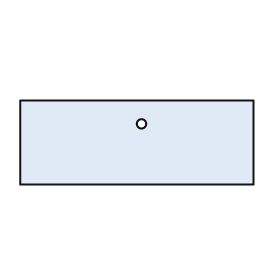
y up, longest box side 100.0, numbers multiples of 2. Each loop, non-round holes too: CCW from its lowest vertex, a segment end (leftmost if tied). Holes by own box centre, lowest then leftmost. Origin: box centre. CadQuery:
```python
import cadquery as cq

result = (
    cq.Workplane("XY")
    .moveTo(-50.0, -18.0)
    .lineTo(50.0, -18.0)
    .lineTo(50.0, 18.0)
    .lineTo(-50.0, 18.0)
    .close()
    .moveTo(2.0, 8.0)
    .circle(2.0)
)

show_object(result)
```